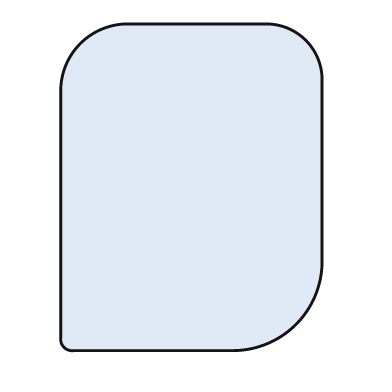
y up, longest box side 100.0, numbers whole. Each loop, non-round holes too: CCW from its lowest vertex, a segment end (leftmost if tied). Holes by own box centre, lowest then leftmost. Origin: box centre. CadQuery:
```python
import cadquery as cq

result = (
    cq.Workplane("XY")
    .moveTo(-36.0, -50.0)
    .lineTo(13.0, -50.0)
    .threePointArc((32.0, -42.0), (40.0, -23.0))
    .lineTo(40.0, 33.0)
    .threePointArc((35.0, 45.0), (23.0, 50.0))
    .lineTo(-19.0, 50.0)
    .threePointArc((-34.0, 44.0), (-40.0, 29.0))
    .lineTo(-40.0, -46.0)
    .threePointArc((-39.0, -49.0), (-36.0, -50.0))
    .close()
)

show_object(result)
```